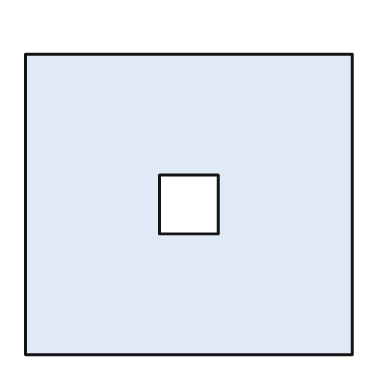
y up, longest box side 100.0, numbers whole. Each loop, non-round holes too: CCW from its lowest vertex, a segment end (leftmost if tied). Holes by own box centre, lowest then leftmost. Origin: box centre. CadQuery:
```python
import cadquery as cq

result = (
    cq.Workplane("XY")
    .moveTo(-50.0, -46.0)
    .lineTo(50.0, -46.0)
    .lineTo(50.0, 46.0)
    .lineTo(-50.0, 46.0)
    .close()
    .moveTo(-9.0, -9.0)
    .lineTo(9.0, -9.0)
    .lineTo(9.0, 9.0)
    .lineTo(-9.0, 9.0)
    .close()
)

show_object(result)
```